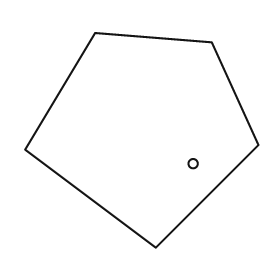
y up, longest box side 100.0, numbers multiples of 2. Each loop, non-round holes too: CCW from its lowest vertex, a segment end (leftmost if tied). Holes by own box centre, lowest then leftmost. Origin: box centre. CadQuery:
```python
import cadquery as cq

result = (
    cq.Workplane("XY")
    .moveTo(6.0, -46.0)
    .lineTo(50.0, -2.0)
    .lineTo(30.0, 42.0)
    .lineTo(-20.0, 46.0)
    .lineTo(-50.0, -4.0)
    .close()
    .moveTo(22.0, -10.0)
    .circle(2.0)
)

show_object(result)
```